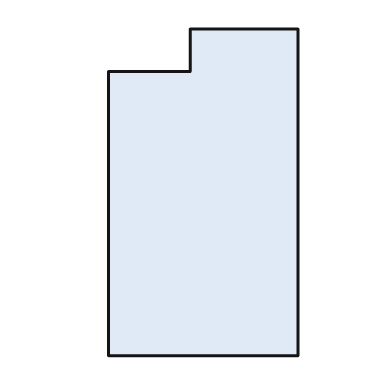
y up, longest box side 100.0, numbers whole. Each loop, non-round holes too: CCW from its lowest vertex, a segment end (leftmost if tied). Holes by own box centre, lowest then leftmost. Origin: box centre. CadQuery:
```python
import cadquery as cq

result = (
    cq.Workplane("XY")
    .moveTo(-29.0, -50.0)
    .lineTo(29.0, -50.0)
    .lineTo(29.0, 50.0)
    .lineTo(-4.0, 50.0)
    .lineTo(-4.0, 37.0)
    .lineTo(-29.0, 37.0)
    .close()
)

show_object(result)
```